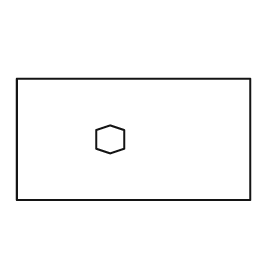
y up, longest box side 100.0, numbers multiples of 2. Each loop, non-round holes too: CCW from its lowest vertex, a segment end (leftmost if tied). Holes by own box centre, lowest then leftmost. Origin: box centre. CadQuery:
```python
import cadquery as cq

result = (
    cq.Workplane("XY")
    .moveTo(-50.0, -26.0)
    .lineTo(50.0, -26.0)
    .lineTo(50.0, 26.0)
    .lineTo(-50.0, 26.0)
    .close()
    .moveTo(-10.0, -6.0)
    .lineTo(-4.0, -4.0)
    .lineTo(-4.0, 4.0)
    .lineTo(-10.0, 6.0)
    .lineTo(-16.0, 4.0)
    .lineTo(-16.0, -4.0)
    .close()
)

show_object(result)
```